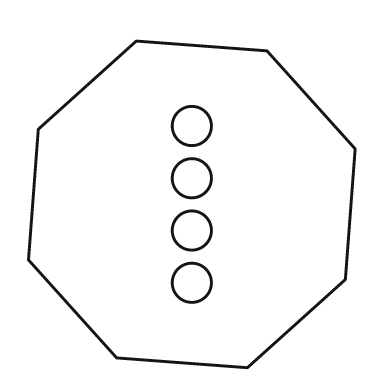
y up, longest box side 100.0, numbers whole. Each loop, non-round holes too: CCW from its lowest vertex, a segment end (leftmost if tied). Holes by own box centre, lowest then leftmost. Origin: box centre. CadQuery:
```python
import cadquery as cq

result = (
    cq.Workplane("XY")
    .moveTo(17.0, -50.0)
    .lineTo(47.0, -23.0)
    .lineTo(50.0, 17.0)
    .lineTo(23.0, 47.0)
    .lineTo(-17.0, 50.0)
    .lineTo(-47.0, 23.0)
    .lineTo(-50.0, -17.0)
    .lineTo(-23.0, -47.0)
    .close()
    .moveTo(0.0, -24.0)
    .circle(6.0)
    .moveTo(0.0, -8.0)
    .circle(6.0)
    .moveTo(0.0, 8.0)
    .circle(6.0)
    .moveTo(0.0, 24.0)
    .circle(6.0)
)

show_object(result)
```